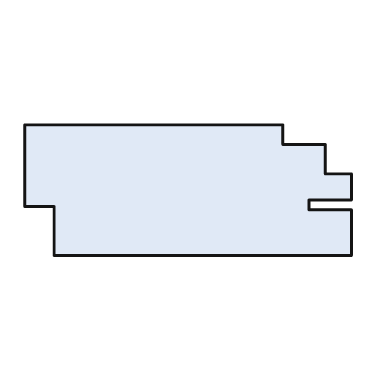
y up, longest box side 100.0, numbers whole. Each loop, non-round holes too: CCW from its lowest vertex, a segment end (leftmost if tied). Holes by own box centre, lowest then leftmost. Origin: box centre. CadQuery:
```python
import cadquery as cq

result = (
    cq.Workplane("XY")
    .moveTo(-41.0, -20.0)
    .lineTo(50.0, -20.0)
    .lineTo(50.0, -6.0)
    .lineTo(37.0, -6.0)
    .lineTo(37.0, -3.0)
    .lineTo(50.0, -3.0)
    .lineTo(50.0, 5.0)
    .lineTo(42.0, 5.0)
    .lineTo(42.0, 14.0)
    .lineTo(29.0, 14.0)
    .lineTo(29.0, 20.0)
    .lineTo(-50.0, 20.0)
    .lineTo(-50.0, -5.0)
    .lineTo(-41.0, -5.0)
    .close()
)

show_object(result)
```